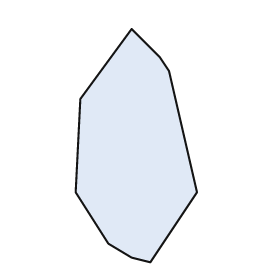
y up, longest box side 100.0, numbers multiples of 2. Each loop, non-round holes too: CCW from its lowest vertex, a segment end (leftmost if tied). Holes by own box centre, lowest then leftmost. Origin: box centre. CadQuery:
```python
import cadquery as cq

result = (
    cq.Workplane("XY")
    .moveTo(6.0, -50.0)
    .lineTo(26.0, -20.0)
    .lineTo(14.0, 32.0)
    .lineTo(10.0, 38.0)
    .lineTo(-2.0, 50.0)
    .lineTo(-24.0, 20.0)
    .lineTo(-26.0, -20.0)
    .lineTo(-12.0, -42.0)
    .lineTo(-2.0, -48.0)
    .close()
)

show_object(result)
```